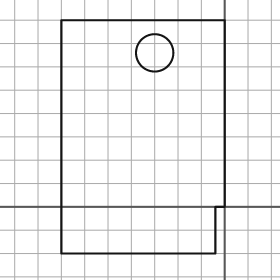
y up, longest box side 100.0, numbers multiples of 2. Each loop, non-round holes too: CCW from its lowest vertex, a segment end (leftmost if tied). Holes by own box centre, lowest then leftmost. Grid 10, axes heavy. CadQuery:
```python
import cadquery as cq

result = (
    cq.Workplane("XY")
    .moveTo(-70.0, -20.0)
    .lineTo(-4.0, -20.0)
    .lineTo(-4.0, 0.0)
    .lineTo(0.0, 0.0)
    .lineTo(0.0, 80.0)
    .lineTo(-70.0, 80.0)
    .close()
    .moveTo(-30.0, 66.0)
    .circle(8.0)
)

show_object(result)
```